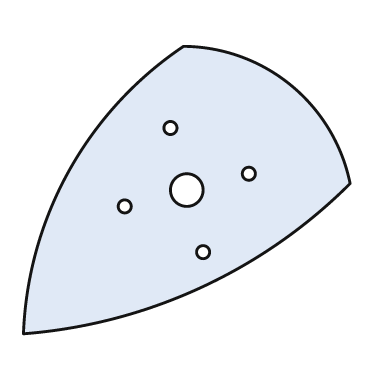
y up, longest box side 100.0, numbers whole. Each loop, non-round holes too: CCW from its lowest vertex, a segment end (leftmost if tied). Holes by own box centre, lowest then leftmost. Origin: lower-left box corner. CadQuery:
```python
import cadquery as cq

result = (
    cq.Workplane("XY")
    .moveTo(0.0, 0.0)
    .threePointArc((54.0, 14.0), (100.0, 46.0))
    .threePointArc((82.0, 76.0), (49.0, 88.0))
    .threePointArc((14.0, 50.0), (0.0, 0.0))
    .close()
    .moveTo(55.0, 25.0)
    .circle(2.0)
    .moveTo(31.0, 39.0)
    .circle(2.0)
    .moveTo(50.0, 44.0)
    .circle(5.0)
    .moveTo(69.0, 49.0)
    .circle(2.0)
    .moveTo(45.0, 63.0)
    .circle(2.0)
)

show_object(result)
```